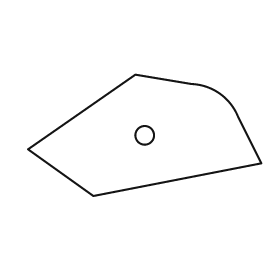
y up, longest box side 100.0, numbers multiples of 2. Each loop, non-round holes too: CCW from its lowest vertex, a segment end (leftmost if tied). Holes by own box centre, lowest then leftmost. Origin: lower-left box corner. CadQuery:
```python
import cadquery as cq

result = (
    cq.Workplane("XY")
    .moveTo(28.0, 0.0)
    .lineTo(100.0, 14.0)
    .lineTo(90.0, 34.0)
    .threePointArc((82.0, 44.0), (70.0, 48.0))
    .lineTo(46.0, 52.0)
    .lineTo(0.0, 20.0)
    .close()
    .moveTo(50.0, 26.0)
    .circle(4.0)
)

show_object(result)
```